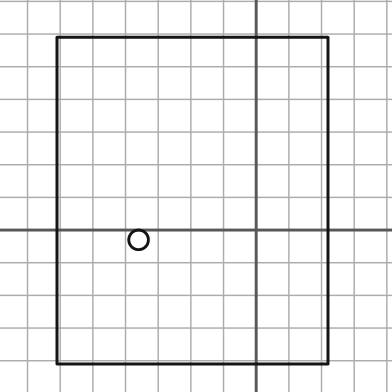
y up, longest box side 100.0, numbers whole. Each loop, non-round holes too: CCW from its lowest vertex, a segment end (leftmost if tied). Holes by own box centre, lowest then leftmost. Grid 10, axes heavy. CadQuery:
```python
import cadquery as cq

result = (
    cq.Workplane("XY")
    .moveTo(-61.0, -41.0)
    .lineTo(22.0, -41.0)
    .lineTo(22.0, 59.0)
    .lineTo(-61.0, 59.0)
    .close()
    .moveTo(-36.0, -3.0)
    .circle(3.0)
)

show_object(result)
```